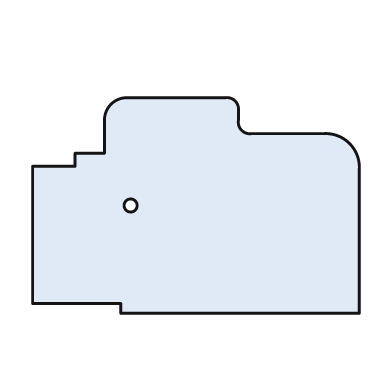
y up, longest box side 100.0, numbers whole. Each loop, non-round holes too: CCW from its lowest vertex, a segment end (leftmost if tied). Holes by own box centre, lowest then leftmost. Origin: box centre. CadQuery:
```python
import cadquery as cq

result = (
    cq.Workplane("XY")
    .moveTo(-23.0, -33.0)
    .lineTo(50.0, -33.0)
    .lineTo(50.0, 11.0)
    .threePointArc((47.0, 19.0), (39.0, 22.0))
    .lineTo(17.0, 22.0)
    .threePointArc((14.0, 23.0), (13.0, 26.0))
    .lineTo(13.0, 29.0)
    .threePointArc((12.0, 32.0), (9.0, 33.0))
    .lineTo(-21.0, 33.0)
    .threePointArc((-26.0, 31.0), (-28.0, 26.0))
    .lineTo(-28.0, 16.0)
    .lineTo(-37.0, 16.0)
    .lineTo(-37.0, 12.0)
    .lineTo(-50.0, 12.0)
    .lineTo(-50.0, -30.0)
    .lineTo(-23.0, -30.0)
    .close()
    .moveTo(-20.0, 0.0)
    .circle(2.0)
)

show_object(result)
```